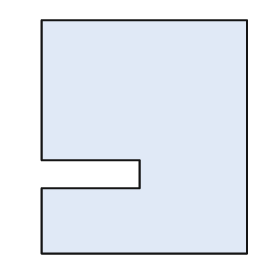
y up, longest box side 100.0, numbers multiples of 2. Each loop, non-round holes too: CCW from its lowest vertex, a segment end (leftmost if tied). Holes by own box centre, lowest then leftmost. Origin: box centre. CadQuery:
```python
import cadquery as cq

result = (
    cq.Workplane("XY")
    .moveTo(-44.0, -50.0)
    .lineTo(44.0, -50.0)
    .lineTo(44.0, 50.0)
    .lineTo(-44.0, 50.0)
    .lineTo(-44.0, -10.0)
    .lineTo(-2.0, -10.0)
    .lineTo(-2.0, -22.0)
    .lineTo(-44.0, -22.0)
    .close()
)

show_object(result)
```